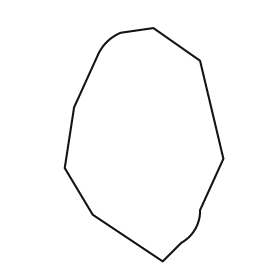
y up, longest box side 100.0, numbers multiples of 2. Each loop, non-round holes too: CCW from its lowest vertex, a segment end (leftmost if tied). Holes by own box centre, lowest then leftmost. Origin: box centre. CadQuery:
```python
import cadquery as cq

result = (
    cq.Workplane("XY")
    .moveTo(8.0, -50.0)
    .lineTo(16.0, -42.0)
    .threePointArc((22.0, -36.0), (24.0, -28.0))
    .lineTo(34.0, -6.0)
    .lineTo(24.0, 36.0)
    .lineTo(4.0, 50.0)
    .lineTo(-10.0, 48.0)
    .threePointArc((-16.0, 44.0), (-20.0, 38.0))
    .lineTo(-30.0, 16.0)
    .lineTo(-34.0, -10.0)
    .lineTo(-22.0, -30.0)
    .close()
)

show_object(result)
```